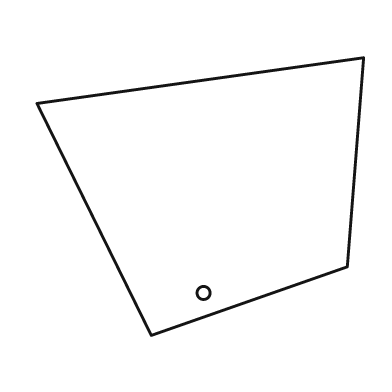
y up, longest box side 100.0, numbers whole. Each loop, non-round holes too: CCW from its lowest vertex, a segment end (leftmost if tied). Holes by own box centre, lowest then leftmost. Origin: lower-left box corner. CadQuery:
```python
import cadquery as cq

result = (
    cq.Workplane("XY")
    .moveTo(35.0, 0.0)
    .lineTo(95.0, 21.0)
    .lineTo(100.0, 85.0)
    .lineTo(0.0, 71.0)
    .close()
    .moveTo(51.0, 13.0)
    .circle(2.0)
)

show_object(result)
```